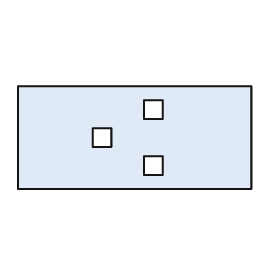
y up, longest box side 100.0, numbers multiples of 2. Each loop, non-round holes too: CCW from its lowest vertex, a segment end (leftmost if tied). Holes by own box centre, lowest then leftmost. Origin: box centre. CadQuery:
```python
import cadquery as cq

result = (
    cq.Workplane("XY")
    .moveTo(-50.0, -22.0)
    .lineTo(50.0, -22.0)
    .lineTo(50.0, 22.0)
    .lineTo(-50.0, 22.0)
    .close()
    .moveTo(4.0, -16.0)
    .lineTo(12.0, -16.0)
    .lineTo(12.0, -8.0)
    .lineTo(4.0, -8.0)
    .close()
    .moveTo(-18.0, -4.0)
    .lineTo(-10.0, -4.0)
    .lineTo(-10.0, 4.0)
    .lineTo(-18.0, 4.0)
    .close()
    .moveTo(4.0, 8.0)
    .lineTo(12.0, 8.0)
    .lineTo(12.0, 16.0)
    .lineTo(4.0, 16.0)
    .close()
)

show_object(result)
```